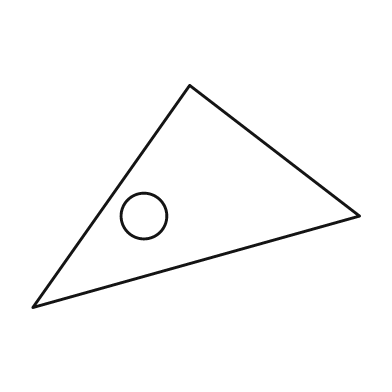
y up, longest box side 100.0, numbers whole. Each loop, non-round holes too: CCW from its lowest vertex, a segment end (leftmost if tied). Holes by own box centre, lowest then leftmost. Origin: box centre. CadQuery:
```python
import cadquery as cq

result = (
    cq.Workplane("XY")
    .moveTo(-50.0, -34.0)
    .lineTo(50.0, -6.0)
    .lineTo(-2.0, 34.0)
    .close()
    .moveTo(-16.0, -6.0)
    .circle(7.0)
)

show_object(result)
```